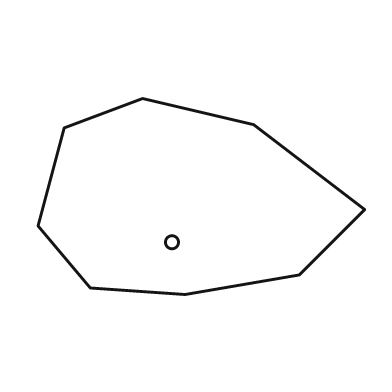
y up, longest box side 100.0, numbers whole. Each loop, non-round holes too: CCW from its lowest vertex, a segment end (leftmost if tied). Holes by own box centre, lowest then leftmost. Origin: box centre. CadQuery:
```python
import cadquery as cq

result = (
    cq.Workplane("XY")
    .moveTo(-5.0, -30.0)
    .lineTo(30.0, -24.0)
    .lineTo(50.0, -4.0)
    .lineTo(16.0, 22.0)
    .lineTo(-18.0, 30.0)
    .lineTo(-42.0, 21.0)
    .lineTo(-50.0, -9.0)
    .lineTo(-34.0, -28.0)
    .close()
    .moveTo(-9.0, -14.0)
    .circle(2.0)
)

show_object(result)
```